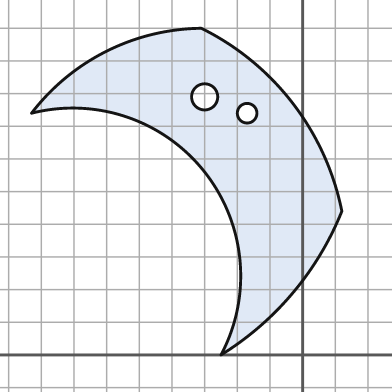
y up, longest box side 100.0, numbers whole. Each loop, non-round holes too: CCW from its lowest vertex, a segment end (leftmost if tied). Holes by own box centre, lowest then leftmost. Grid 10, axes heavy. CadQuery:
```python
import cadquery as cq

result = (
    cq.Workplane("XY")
    .moveTo(-25.0, 0.0)
    .threePointArc((-3.0, 19.0), (12.0, 44.0))
    .threePointArc((-3.0, 77.0), (-31.0, 100.0))
    .threePointArc((-60.0, 93.0), (-83.0, 74.0))
    .threePointArc((-30.0, 56.0), (-25.0, 0.0))
    .close()
    .moveTo(-17.0, 74.0)
    .circle(3.0)
    .moveTo(-30.0, 79.0)
    .circle(4.0)
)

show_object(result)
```